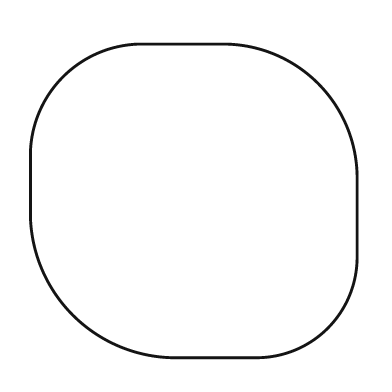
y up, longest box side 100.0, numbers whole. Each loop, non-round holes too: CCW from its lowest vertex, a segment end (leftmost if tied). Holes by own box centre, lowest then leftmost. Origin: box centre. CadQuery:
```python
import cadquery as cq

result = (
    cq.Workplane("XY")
    .moveTo(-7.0, -48.0)
    .lineTo(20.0, -48.0)
    .threePointArc((41.0, -39.0), (50.0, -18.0))
    .lineTo(50.0, 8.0)
    .threePointArc((38.0, 36.0), (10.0, 48.0))
    .lineTo(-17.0, 48.0)
    .threePointArc((-40.0, 38.0), (-50.0, 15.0))
    .lineTo(-50.0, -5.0)
    .threePointArc((-37.0, -35.0), (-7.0, -48.0))
    .close()
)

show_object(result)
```